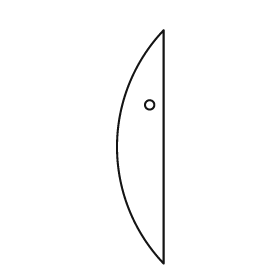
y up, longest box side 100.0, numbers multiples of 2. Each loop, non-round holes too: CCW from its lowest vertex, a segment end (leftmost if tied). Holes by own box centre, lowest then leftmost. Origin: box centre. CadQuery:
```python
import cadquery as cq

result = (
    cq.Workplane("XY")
    .moveTo(10.0, -50.0)
    .lineTo(10.0, 50.0)
    .threePointArc((-10.0, 0.0), (10.0, -50.0))
    .close()
    .moveTo(4.0, 18.0)
    .circle(2.0)
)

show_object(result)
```